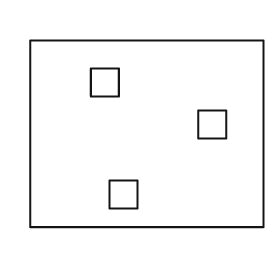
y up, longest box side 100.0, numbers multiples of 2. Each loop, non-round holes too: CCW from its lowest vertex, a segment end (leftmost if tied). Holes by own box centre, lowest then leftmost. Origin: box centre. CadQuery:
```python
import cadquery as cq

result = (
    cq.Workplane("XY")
    .moveTo(-50.0, -40.0)
    .lineTo(50.0, -40.0)
    .lineTo(50.0, 40.0)
    .lineTo(-50.0, 40.0)
    .close()
    .moveTo(-16.0, -32.0)
    .lineTo(-4.0, -32.0)
    .lineTo(-4.0, -20.0)
    .lineTo(-16.0, -20.0)
    .close()
    .moveTo(22.0, -2.0)
    .lineTo(34.0, -2.0)
    .lineTo(34.0, 10.0)
    .lineTo(22.0, 10.0)
    .close()
    .moveTo(-24.0, 16.0)
    .lineTo(-12.0, 16.0)
    .lineTo(-12.0, 28.0)
    .lineTo(-24.0, 28.0)
    .close()
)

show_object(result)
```